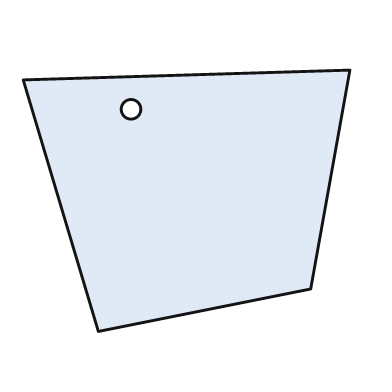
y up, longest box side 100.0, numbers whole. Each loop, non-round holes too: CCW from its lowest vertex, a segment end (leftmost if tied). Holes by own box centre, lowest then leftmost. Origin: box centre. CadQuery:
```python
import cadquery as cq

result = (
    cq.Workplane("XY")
    .moveTo(-27.0, -40.0)
    .lineTo(38.0, -27.0)
    .lineTo(50.0, 40.0)
    .lineTo(-50.0, 37.0)
    .close()
    .moveTo(-17.0, 28.0)
    .circle(3.0)
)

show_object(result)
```